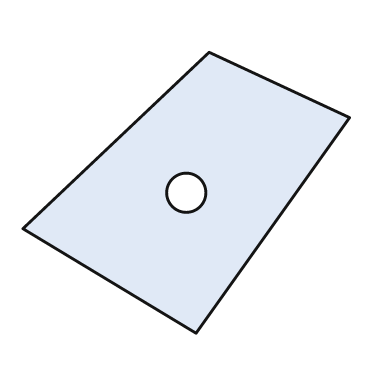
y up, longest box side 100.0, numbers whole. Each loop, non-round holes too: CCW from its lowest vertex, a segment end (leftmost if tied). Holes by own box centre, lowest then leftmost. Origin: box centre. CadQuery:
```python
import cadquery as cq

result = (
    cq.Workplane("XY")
    .moveTo(3.0, -43.0)
    .lineTo(50.0, 23.0)
    .lineTo(7.0, 43.0)
    .lineTo(-50.0, -11.0)
    .close()
    .moveTo(0.0, 0.0)
    .circle(6.0)
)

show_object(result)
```